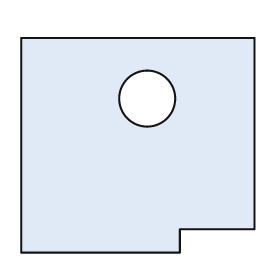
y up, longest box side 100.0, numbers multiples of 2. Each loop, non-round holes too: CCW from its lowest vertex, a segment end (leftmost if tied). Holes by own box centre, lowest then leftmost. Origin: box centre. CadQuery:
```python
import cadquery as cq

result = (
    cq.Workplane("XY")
    .moveTo(-50.0, -46.0)
    .lineTo(18.0, -46.0)
    .lineTo(18.0, -36.0)
    .lineTo(50.0, -36.0)
    .lineTo(50.0, 46.0)
    .lineTo(-50.0, 46.0)
    .close()
    .moveTo(4.0, 20.0)
    .circle(12.0)
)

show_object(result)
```